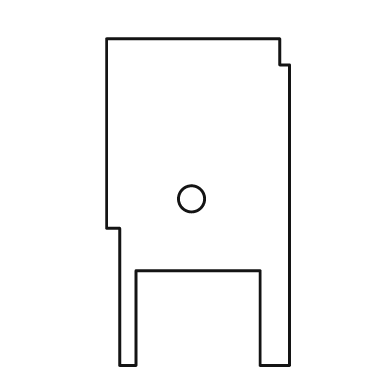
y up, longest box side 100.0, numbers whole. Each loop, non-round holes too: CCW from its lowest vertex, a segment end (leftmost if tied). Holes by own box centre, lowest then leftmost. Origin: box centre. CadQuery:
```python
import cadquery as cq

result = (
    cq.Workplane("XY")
    .moveTo(-24.0, -50.0)
    .lineTo(-19.0, -50.0)
    .lineTo(-19.0, -21.0)
    .lineTo(19.0, -21.0)
    .lineTo(19.0, -50.0)
    .lineTo(28.0, -50.0)
    .lineTo(28.0, 42.0)
    .lineTo(25.0, 42.0)
    .lineTo(25.0, 50.0)
    .lineTo(-28.0, 50.0)
    .lineTo(-28.0, -8.0)
    .lineTo(-24.0, -8.0)
    .close()
    .moveTo(-2.0, 1.0)
    .circle(4.0)
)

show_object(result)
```